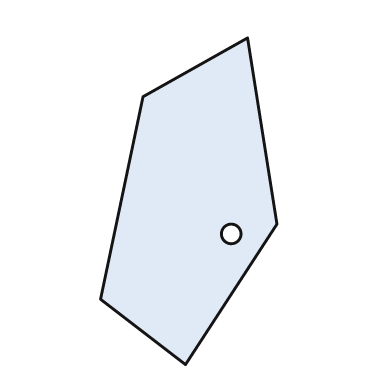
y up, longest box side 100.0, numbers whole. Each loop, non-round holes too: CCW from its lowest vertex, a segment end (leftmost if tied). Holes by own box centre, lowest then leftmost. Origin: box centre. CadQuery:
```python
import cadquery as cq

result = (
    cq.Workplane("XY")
    .moveTo(-1.0, -50.0)
    .lineTo(27.0, -7.0)
    .lineTo(18.0, 50.0)
    .lineTo(-14.0, 32.0)
    .lineTo(-27.0, -30.0)
    .close()
    .moveTo(13.0, -10.0)
    .circle(3.0)
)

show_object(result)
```